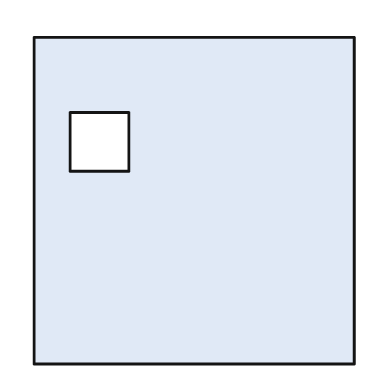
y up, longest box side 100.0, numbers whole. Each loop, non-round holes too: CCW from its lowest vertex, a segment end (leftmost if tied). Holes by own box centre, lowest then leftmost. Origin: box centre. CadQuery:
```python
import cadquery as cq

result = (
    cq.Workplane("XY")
    .moveTo(-49.0, -50.0)
    .lineTo(49.0, -50.0)
    .lineTo(49.0, 50.0)
    .lineTo(-49.0, 50.0)
    .close()
    .moveTo(-38.0, 9.0)
    .lineTo(-20.0, 9.0)
    .lineTo(-20.0, 27.0)
    .lineTo(-38.0, 27.0)
    .close()
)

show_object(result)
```